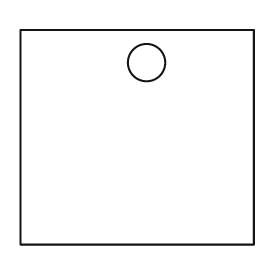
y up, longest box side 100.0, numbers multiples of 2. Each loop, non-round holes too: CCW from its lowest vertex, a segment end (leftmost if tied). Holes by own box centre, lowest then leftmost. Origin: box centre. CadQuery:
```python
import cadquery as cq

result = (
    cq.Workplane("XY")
    .moveTo(-50.0, -46.0)
    .lineTo(50.0, -46.0)
    .lineTo(50.0, 46.0)
    .lineTo(-50.0, 46.0)
    .close()
    .moveTo(4.0, 32.0)
    .circle(8.0)
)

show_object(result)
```